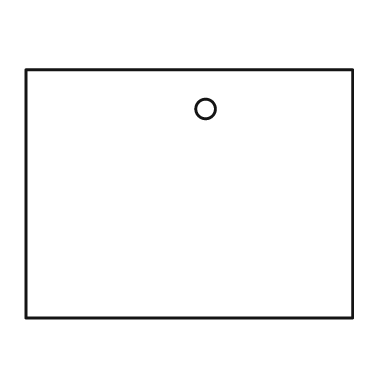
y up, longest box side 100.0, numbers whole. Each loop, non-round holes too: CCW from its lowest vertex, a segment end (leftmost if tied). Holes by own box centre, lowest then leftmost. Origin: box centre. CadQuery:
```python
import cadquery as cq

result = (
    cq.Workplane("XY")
    .moveTo(-50.0, -38.0)
    .lineTo(50.0, -38.0)
    .lineTo(50.0, 38.0)
    .lineTo(-50.0, 38.0)
    .close()
    .moveTo(5.0, 26.0)
    .circle(3.0)
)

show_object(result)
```